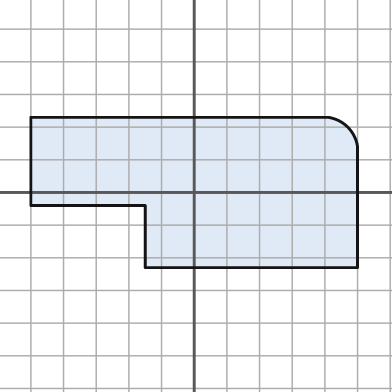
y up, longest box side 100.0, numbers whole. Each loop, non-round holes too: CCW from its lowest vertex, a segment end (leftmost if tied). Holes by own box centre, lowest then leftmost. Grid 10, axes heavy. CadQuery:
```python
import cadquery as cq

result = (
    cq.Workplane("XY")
    .moveTo(-15.0, -23.0)
    .lineTo(50.0, -23.0)
    .lineTo(50.0, 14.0)
    .threePointArc((47.0, 20.0), (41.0, 23.0))
    .lineTo(-50.0, 23.0)
    .lineTo(-50.0, -4.0)
    .lineTo(-15.0, -4.0)
    .close()
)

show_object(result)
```